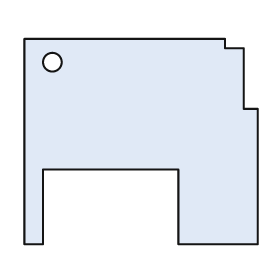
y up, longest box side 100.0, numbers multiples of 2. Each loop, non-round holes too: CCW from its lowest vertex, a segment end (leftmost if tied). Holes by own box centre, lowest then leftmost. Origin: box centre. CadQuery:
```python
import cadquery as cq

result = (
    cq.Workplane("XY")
    .moveTo(-50.0, -44.0)
    .lineTo(-42.0, -44.0)
    .lineTo(-42.0, -12.0)
    .lineTo(16.0, -12.0)
    .lineTo(16.0, -44.0)
    .lineTo(50.0, -44.0)
    .lineTo(50.0, 14.0)
    .lineTo(44.0, 14.0)
    .lineTo(44.0, 40.0)
    .lineTo(36.0, 40.0)
    .lineTo(36.0, 44.0)
    .lineTo(-50.0, 44.0)
    .close()
    .moveTo(-38.0, 34.0)
    .circle(4.0)
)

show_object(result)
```